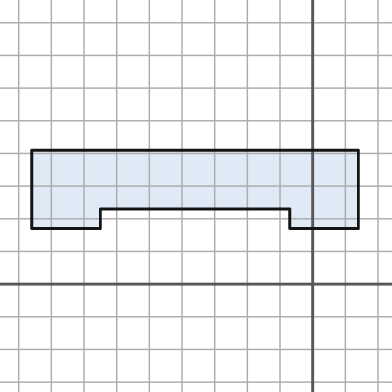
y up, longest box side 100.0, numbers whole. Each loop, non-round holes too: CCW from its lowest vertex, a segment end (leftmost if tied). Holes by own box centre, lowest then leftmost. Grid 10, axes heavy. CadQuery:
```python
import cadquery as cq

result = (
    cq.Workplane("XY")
    .moveTo(-86.0, 17.0)
    .lineTo(-65.0, 17.0)
    .lineTo(-65.0, 23.0)
    .lineTo(-7.0, 23.0)
    .lineTo(-7.0, 17.0)
    .lineTo(14.0, 17.0)
    .lineTo(14.0, 41.0)
    .lineTo(-86.0, 41.0)
    .close()
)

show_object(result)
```